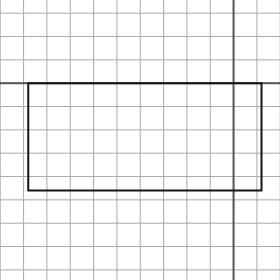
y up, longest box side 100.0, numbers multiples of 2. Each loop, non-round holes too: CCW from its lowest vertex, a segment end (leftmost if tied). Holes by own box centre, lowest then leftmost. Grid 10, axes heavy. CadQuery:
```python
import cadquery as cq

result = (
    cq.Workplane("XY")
    .moveTo(-88.0, -46.0)
    .lineTo(12.0, -46.0)
    .lineTo(12.0, 0.0)
    .lineTo(-88.0, 0.0)
    .close()
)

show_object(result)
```